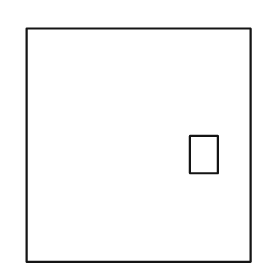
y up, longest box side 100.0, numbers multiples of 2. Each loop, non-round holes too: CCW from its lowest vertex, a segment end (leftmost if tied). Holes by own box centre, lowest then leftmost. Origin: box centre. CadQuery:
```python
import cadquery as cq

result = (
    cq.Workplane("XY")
    .moveTo(-48.0, -50.0)
    .lineTo(48.0, -50.0)
    .lineTo(48.0, 50.0)
    .lineTo(-48.0, 50.0)
    .close()
    .moveTo(22.0, -12.0)
    .lineTo(34.0, -12.0)
    .lineTo(34.0, 4.0)
    .lineTo(22.0, 4.0)
    .close()
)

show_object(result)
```